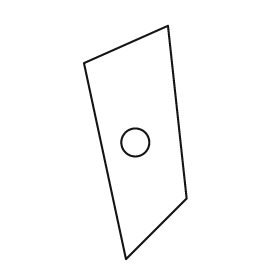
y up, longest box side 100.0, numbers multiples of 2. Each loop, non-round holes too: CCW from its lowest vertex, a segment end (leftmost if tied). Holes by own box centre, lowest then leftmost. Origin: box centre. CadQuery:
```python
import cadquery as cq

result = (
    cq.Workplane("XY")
    .moveTo(-4.0, -50.0)
    .lineTo(22.0, -24.0)
    .lineTo(14.0, 50.0)
    .lineTo(-22.0, 34.0)
    .close()
    .moveTo(0.0, 0.0)
    .circle(6.0)
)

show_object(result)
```